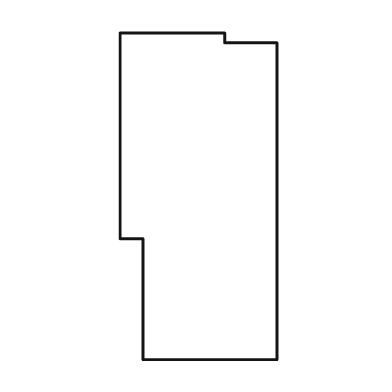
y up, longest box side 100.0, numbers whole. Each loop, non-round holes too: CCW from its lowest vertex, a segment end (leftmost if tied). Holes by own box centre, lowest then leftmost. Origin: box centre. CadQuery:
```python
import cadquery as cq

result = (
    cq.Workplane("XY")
    .moveTo(-17.0, -50.0)
    .lineTo(24.0, -50.0)
    .lineTo(24.0, 47.0)
    .lineTo(8.0, 47.0)
    .lineTo(8.0, 50.0)
    .lineTo(-24.0, 50.0)
    .lineTo(-24.0, -13.0)
    .lineTo(-17.0, -13.0)
    .close()
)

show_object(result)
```